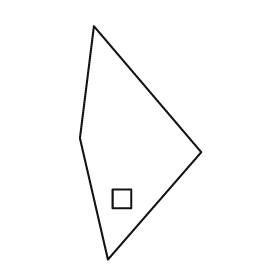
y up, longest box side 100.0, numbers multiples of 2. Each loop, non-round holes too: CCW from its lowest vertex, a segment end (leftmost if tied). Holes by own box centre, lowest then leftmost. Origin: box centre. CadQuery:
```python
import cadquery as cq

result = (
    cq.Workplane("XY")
    .moveTo(-14.0, -50.0)
    .lineTo(26.0, -4.0)
    .lineTo(-20.0, 50.0)
    .lineTo(-26.0, 2.0)
    .close()
    .moveTo(-12.0, -28.0)
    .lineTo(-4.0, -28.0)
    .lineTo(-4.0, -20.0)
    .lineTo(-12.0, -20.0)
    .close()
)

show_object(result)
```